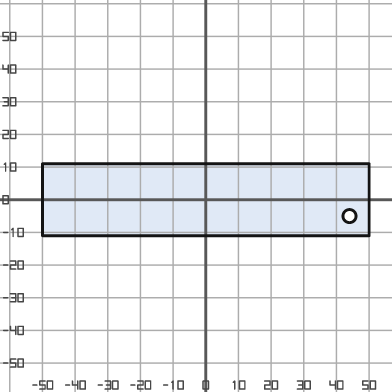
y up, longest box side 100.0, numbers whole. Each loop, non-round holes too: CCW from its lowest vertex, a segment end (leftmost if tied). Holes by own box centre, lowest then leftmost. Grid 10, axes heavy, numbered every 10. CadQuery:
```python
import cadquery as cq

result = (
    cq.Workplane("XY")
    .moveTo(-50.0, -11.0)
    .lineTo(50.0, -11.0)
    .lineTo(50.0, 11.0)
    .lineTo(-50.0, 11.0)
    .close()
    .moveTo(44.0, -5.0)
    .circle(2.0)
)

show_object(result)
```